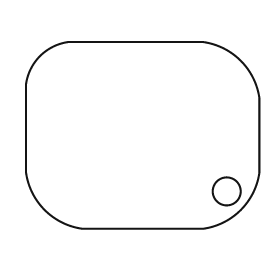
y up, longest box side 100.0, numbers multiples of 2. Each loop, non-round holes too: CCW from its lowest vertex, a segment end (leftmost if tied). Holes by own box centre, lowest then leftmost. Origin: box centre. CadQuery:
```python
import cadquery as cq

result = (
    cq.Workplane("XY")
    .moveTo(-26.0, -40.0)
    .lineTo(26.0, -40.0)
    .threePointArc((42.0, -32.0), (50.0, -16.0))
    .lineTo(50.0, 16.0)
    .threePointArc((42.0, 32.0), (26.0, 40.0))
    .lineTo(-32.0, 40.0)
    .threePointArc((-44.0, 34.0), (-50.0, 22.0))
    .lineTo(-50.0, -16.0)
    .threePointArc((-42.0, -32.0), (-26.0, -40.0))
    .close()
    .moveTo(36.0, -24.0)
    .circle(6.0)
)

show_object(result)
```